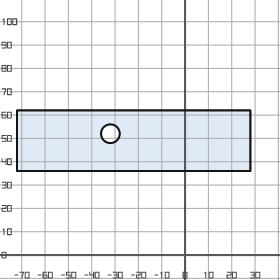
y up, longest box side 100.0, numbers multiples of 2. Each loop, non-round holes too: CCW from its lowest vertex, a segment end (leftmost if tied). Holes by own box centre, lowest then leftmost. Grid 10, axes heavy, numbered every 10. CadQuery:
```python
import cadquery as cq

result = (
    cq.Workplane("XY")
    .moveTo(-72.0, 36.0)
    .lineTo(28.0, 36.0)
    .lineTo(28.0, 62.0)
    .lineTo(-72.0, 62.0)
    .close()
    .moveTo(-32.0, 52.0)
    .circle(4.0)
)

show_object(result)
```